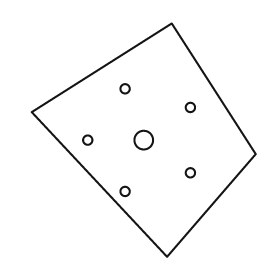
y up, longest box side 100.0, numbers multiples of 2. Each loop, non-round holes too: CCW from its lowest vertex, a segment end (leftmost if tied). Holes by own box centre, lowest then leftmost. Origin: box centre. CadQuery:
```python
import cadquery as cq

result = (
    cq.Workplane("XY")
    .moveTo(10.0, -50.0)
    .lineTo(48.0, -6.0)
    .lineTo(12.0, 50.0)
    .lineTo(-48.0, 12.0)
    .close()
    .moveTo(-8.0, -22.0)
    .circle(2.0)
    .moveTo(20.0, -14.0)
    .circle(2.0)
    .moveTo(-24.0, 0.0)
    .circle(2.0)
    .moveTo(0.0, 0.0)
    .circle(4.0)
    .moveTo(20.0, 14.0)
    .circle(2.0)
    .moveTo(-8.0, 22.0)
    .circle(2.0)
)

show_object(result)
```